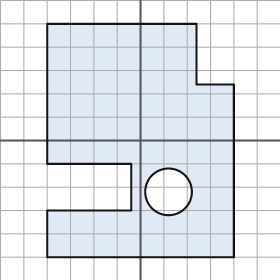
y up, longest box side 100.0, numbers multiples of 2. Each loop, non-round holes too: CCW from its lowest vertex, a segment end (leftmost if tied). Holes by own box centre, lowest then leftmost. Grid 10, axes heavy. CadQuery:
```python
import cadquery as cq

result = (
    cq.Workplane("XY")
    .moveTo(-40.0, -50.0)
    .lineTo(40.0, -50.0)
    .lineTo(40.0, 24.0)
    .lineTo(24.0, 24.0)
    .lineTo(24.0, 50.0)
    .lineTo(-40.0, 50.0)
    .lineTo(-40.0, -10.0)
    .lineTo(-4.0, -10.0)
    .lineTo(-4.0, -30.0)
    .lineTo(-40.0, -30.0)
    .close()
    .moveTo(12.0, -22.0)
    .circle(10.0)
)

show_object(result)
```